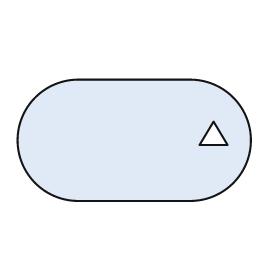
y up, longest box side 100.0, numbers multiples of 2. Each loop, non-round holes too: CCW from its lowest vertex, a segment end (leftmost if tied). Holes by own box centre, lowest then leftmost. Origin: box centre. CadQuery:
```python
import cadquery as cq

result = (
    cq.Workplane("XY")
    .moveTo(-24.0, -26.0)
    .lineTo(24.0, -26.0)
    .threePointArc((50.0, 0.0), (24.0, 26.0))
    .lineTo(-24.0, 26.0)
    .threePointArc((-50.0, 0.0), (-24.0, -26.0))
    .close()
    .moveTo(28.0, -2.0)
    .lineTo(40.0, -2.0)
    .lineTo(34.0, 8.0)
    .close()
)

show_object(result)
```